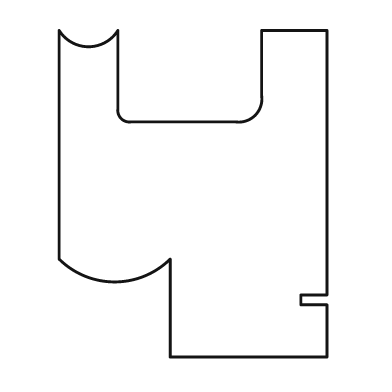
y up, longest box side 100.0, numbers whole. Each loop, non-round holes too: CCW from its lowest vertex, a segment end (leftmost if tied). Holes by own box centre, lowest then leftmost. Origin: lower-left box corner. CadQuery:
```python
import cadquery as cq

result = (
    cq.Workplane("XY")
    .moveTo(34.0, 0.0)
    .lineTo(82.0, 0.0)
    .lineTo(82.0, 16.0)
    .lineTo(74.0, 16.0)
    .lineTo(74.0, 19.0)
    .lineTo(82.0, 19.0)
    .lineTo(82.0, 100.0)
    .lineTo(62.0, 100.0)
    .lineTo(62.0, 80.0)
    .threePointArc((60.0, 74.0), (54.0, 72.0))
    .lineTo(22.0, 72.0)
    .threePointArc((19.0, 73.0), (18.0, 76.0))
    .lineTo(18.0, 100.0)
    .threePointArc((9.0, 95.0), (0.0, 100.0))
    .lineTo(0.0, 30.0)
    .threePointArc((17.0, 23.0), (34.0, 30.0))
    .close()
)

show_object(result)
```